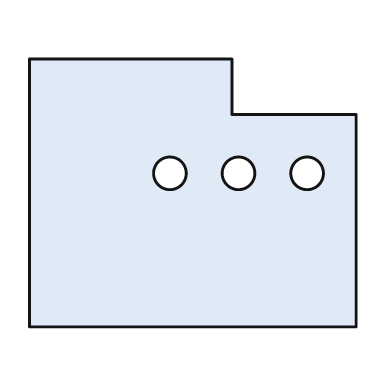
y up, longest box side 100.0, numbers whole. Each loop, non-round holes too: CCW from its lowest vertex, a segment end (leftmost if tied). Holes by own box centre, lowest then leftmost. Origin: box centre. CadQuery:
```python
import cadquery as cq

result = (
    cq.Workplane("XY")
    .moveTo(-50.0, -41.0)
    .lineTo(50.0, -41.0)
    .lineTo(50.0, 24.0)
    .lineTo(12.0, 24.0)
    .lineTo(12.0, 41.0)
    .lineTo(-50.0, 41.0)
    .close()
    .moveTo(-7.0, 6.0)
    .circle(5.0)
    .moveTo(14.0, 6.0)
    .circle(5.0)
    .moveTo(35.0, 6.0)
    .circle(5.0)
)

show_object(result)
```